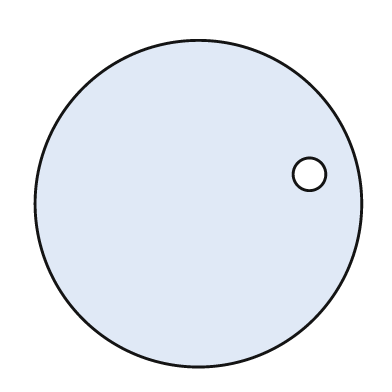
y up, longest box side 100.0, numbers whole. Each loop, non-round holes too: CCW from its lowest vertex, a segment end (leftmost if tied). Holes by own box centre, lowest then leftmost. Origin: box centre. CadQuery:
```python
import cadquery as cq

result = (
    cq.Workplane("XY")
    .moveTo(0.0, 0.0)
    .circle(50.0)
    .moveTo(34.0, 9.0)
    .circle(5.0)
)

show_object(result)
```